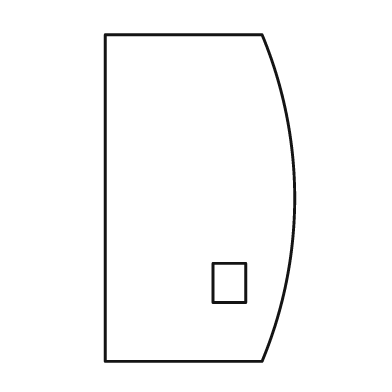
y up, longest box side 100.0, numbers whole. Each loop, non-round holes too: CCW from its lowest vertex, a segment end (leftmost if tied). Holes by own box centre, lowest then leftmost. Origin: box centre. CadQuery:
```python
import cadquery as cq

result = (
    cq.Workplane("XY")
    .moveTo(-29.0, -50.0)
    .lineTo(19.0, -50.0)
    .threePointArc((29.0, 0.0), (19.0, 50.0))
    .lineTo(-29.0, 50.0)
    .close()
    .moveTo(4.0, -32.0)
    .lineTo(14.0, -32.0)
    .lineTo(14.0, -20.0)
    .lineTo(4.0, -20.0)
    .close()
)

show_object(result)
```